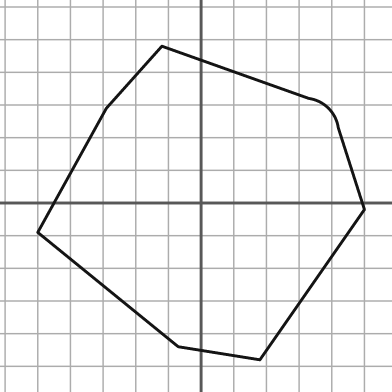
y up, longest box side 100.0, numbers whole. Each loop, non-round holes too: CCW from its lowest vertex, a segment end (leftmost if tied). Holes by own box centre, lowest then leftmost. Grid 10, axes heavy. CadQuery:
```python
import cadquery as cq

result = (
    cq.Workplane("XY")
    .moveTo(18.0, -48.0)
    .lineTo(50.0, -2.0)
    .lineTo(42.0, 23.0)
    .threePointArc((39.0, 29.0), (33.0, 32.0))
    .lineTo(-12.0, 48.0)
    .lineTo(-29.0, 29.0)
    .lineTo(-50.0, -9.0)
    .lineTo(-7.0, -44.0)
    .close()
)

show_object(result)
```